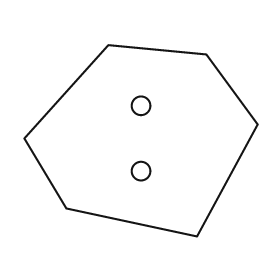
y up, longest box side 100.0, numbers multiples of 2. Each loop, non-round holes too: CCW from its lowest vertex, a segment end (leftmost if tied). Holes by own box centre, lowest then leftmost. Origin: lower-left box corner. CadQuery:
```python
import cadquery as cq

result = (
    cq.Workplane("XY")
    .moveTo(74.0, 0.0)
    .lineTo(100.0, 48.0)
    .lineTo(78.0, 78.0)
    .lineTo(36.0, 82.0)
    .lineTo(0.0, 42.0)
    .lineTo(18.0, 12.0)
    .close()
    .moveTo(50.0, 28.0)
    .circle(4.0)
    .moveTo(50.0, 56.0)
    .circle(4.0)
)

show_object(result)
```